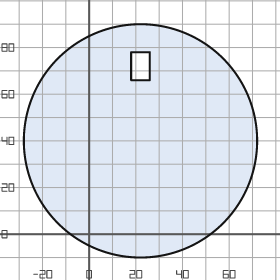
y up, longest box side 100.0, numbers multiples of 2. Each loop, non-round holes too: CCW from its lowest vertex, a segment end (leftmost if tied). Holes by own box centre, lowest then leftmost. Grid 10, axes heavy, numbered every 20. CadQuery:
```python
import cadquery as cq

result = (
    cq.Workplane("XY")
    .moveTo(22.0, 40.0)
    .circle(50.0)
    .moveTo(18.0, 66.0)
    .lineTo(26.0, 66.0)
    .lineTo(26.0, 78.0)
    .lineTo(18.0, 78.0)
    .close()
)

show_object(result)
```